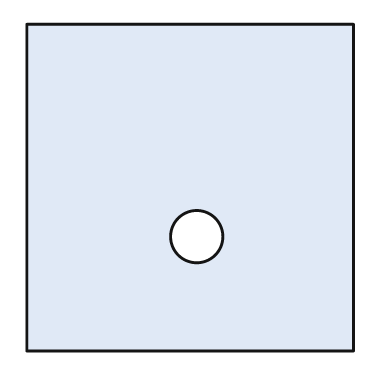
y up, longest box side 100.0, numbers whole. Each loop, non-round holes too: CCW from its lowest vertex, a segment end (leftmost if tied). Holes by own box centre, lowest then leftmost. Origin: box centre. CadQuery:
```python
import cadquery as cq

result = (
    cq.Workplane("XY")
    .moveTo(-50.0, -50.0)
    .lineTo(50.0, -50.0)
    .lineTo(50.0, 50.0)
    .lineTo(-50.0, 50.0)
    .close()
    .moveTo(2.0, -15.0)
    .circle(8.0)
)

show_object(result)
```